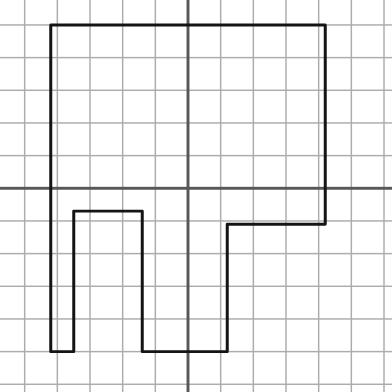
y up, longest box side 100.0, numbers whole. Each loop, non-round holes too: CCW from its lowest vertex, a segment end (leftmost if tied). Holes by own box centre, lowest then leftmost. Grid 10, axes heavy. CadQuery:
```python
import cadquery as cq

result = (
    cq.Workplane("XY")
    .moveTo(-42.0, -50.0)
    .lineTo(-35.0, -50.0)
    .lineTo(-35.0, -7.0)
    .lineTo(-14.0, -7.0)
    .lineTo(-14.0, -50.0)
    .lineTo(12.0, -50.0)
    .lineTo(12.0, -11.0)
    .lineTo(42.0, -11.0)
    .lineTo(42.0, 50.0)
    .lineTo(-42.0, 50.0)
    .close()
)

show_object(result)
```